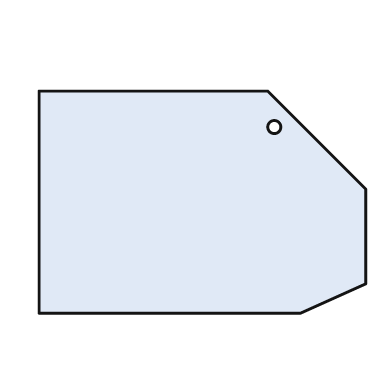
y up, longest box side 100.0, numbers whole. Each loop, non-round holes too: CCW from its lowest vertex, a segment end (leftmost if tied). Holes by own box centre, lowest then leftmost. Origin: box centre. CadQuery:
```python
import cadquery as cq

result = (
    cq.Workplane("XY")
    .moveTo(-50.0, -34.0)
    .lineTo(30.0, -34.0)
    .lineTo(50.0, -25.0)
    .lineTo(50.0, 4.0)
    .lineTo(20.0, 34.0)
    .lineTo(-50.0, 34.0)
    .close()
    .moveTo(22.0, 23.0)
    .circle(2.0)
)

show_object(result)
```